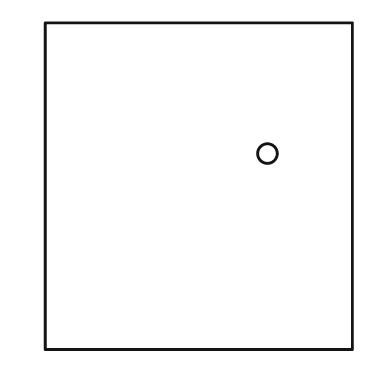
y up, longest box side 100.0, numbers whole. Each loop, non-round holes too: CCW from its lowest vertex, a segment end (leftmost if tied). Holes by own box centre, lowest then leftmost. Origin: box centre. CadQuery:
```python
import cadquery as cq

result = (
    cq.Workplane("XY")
    .moveTo(-47.0, -50.0)
    .lineTo(47.0, -50.0)
    .lineTo(47.0, 50.0)
    .lineTo(-47.0, 50.0)
    .close()
    .moveTo(21.0, 10.0)
    .circle(3.0)
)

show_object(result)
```